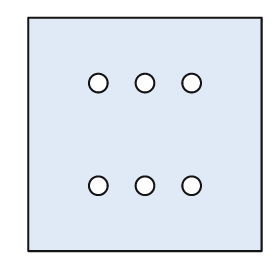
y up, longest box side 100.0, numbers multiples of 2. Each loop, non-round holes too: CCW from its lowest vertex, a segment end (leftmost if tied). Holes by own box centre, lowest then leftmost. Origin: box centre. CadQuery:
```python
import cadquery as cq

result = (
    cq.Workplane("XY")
    .moveTo(-50.0, -50.0)
    .lineTo(50.0, -50.0)
    .lineTo(50.0, 50.0)
    .lineTo(-50.0, 50.0)
    .close()
    .moveTo(-20.0, -22.0)
    .circle(4.0)
    .moveTo(0.0, -22.0)
    .circle(4.0)
    .moveTo(20.0, -22.0)
    .circle(4.0)
    .moveTo(-20.0, 22.0)
    .circle(4.0)
    .moveTo(0.0, 22.0)
    .circle(4.0)
    .moveTo(20.0, 22.0)
    .circle(4.0)
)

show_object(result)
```